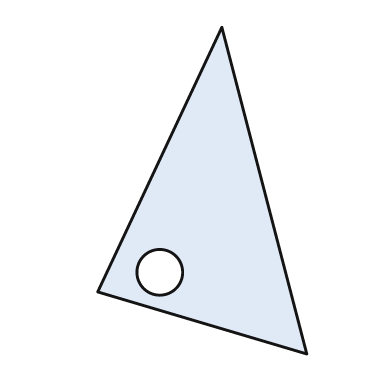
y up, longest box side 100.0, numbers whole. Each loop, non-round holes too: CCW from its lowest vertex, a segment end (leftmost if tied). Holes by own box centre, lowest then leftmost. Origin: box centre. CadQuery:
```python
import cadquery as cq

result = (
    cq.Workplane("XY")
    .moveTo(32.0, -50.0)
    .lineTo(6.0, 50.0)
    .lineTo(-32.0, -31.0)
    .close()
    .moveTo(-13.0, -25.0)
    .circle(7.0)
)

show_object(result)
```